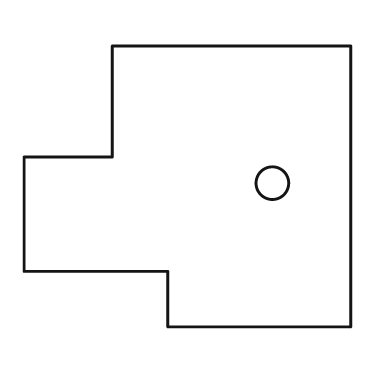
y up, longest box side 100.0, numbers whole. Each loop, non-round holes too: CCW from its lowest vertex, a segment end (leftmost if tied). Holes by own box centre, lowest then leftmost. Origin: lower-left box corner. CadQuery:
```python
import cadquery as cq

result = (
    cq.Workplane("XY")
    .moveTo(44.0, 0.0)
    .lineTo(100.0, 0.0)
    .lineTo(100.0, 86.0)
    .lineTo(27.0, 86.0)
    .lineTo(27.0, 52.0)
    .lineTo(0.0, 52.0)
    .lineTo(0.0, 17.0)
    .lineTo(44.0, 17.0)
    .close()
    .moveTo(76.0, 44.0)
    .circle(5.0)
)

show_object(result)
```